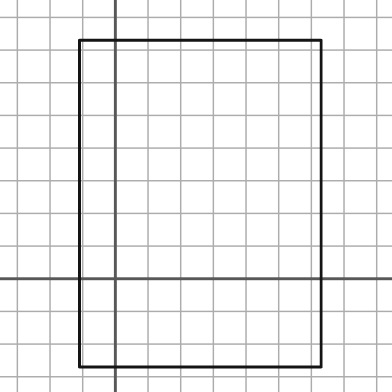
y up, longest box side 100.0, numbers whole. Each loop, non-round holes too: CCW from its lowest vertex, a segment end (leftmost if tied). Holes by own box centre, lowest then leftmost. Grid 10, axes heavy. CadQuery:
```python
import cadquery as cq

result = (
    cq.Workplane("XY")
    .moveTo(-11.0, -27.0)
    .lineTo(63.0, -27.0)
    .lineTo(63.0, 73.0)
    .lineTo(-11.0, 73.0)
    .close()
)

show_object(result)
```